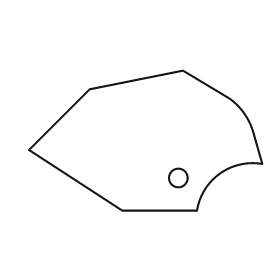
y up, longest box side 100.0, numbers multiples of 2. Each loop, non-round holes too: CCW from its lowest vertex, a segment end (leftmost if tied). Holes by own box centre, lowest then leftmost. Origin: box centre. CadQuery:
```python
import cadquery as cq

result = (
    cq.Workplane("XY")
    .moveTo(-10.0, -30.0)
    .lineTo(22.0, -30.0)
    .threePointArc((32.0, -14.0), (50.0, -10.0))
    .lineTo(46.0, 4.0)
    .threePointArc((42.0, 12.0), (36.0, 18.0))
    .lineTo(16.0, 30.0)
    .lineTo(-24.0, 22.0)
    .lineTo(-50.0, -4.0)
    .close()
    .moveTo(14.0, -16.0)
    .circle(4.0)
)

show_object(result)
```